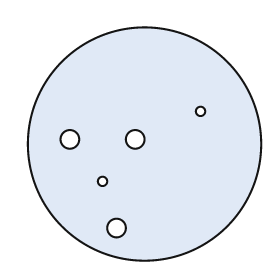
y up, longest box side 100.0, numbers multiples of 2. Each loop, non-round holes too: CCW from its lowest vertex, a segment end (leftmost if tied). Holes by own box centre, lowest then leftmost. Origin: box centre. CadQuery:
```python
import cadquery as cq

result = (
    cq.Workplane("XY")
    .moveTo(0.0, 0.0)
    .circle(50.0)
    .moveTo(-12.0, -36.0)
    .circle(4.0)
    .moveTo(-18.0, -16.0)
    .circle(2.0)
    .moveTo(-32.0, 2.0)
    .circle(4.0)
    .moveTo(-4.0, 2.0)
    .circle(4.0)
    .moveTo(24.0, 14.0)
    .circle(2.0)
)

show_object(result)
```